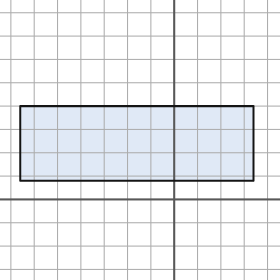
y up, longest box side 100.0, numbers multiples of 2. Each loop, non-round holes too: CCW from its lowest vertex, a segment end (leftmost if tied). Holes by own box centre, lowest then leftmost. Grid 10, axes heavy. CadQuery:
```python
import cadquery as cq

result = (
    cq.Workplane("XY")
    .moveTo(-66.0, 8.0)
    .lineTo(34.0, 8.0)
    .lineTo(34.0, 40.0)
    .lineTo(-66.0, 40.0)
    .close()
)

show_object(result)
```